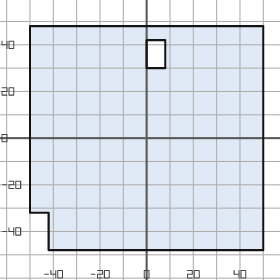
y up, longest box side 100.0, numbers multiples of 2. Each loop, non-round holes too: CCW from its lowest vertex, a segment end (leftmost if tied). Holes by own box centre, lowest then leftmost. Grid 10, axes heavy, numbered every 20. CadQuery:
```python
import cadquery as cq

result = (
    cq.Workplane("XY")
    .moveTo(-42.0, -48.0)
    .lineTo(50.0, -48.0)
    .lineTo(50.0, 48.0)
    .lineTo(-50.0, 48.0)
    .lineTo(-50.0, -32.0)
    .lineTo(-42.0, -32.0)
    .close()
    .moveTo(0.0, 30.0)
    .lineTo(8.0, 30.0)
    .lineTo(8.0, 42.0)
    .lineTo(0.0, 42.0)
    .close()
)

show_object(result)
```